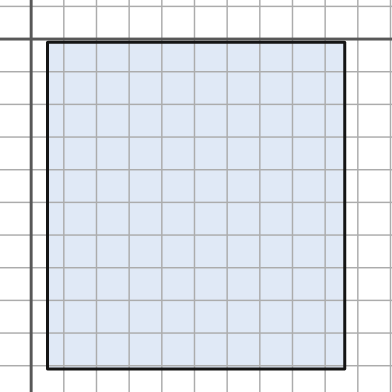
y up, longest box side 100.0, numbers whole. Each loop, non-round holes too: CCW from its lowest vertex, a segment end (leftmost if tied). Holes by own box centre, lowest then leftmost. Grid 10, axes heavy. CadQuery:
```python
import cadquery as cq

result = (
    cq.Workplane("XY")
    .moveTo(5.0, -101.0)
    .lineTo(96.0, -101.0)
    .lineTo(96.0, -1.0)
    .lineTo(5.0, -1.0)
    .close()
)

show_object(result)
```